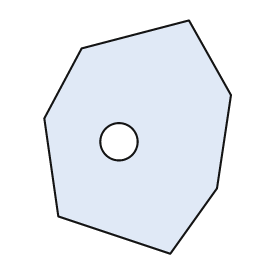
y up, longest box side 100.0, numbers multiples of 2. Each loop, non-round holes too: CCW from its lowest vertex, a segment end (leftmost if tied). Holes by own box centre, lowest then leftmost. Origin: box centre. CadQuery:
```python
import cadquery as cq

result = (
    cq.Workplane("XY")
    .moveTo(14.0, -50.0)
    .lineTo(34.0, -22.0)
    .lineTo(40.0, 18.0)
    .lineTo(22.0, 50.0)
    .lineTo(-24.0, 38.0)
    .lineTo(-40.0, 8.0)
    .lineTo(-34.0, -34.0)
    .close()
    .moveTo(-8.0, -2.0)
    .circle(8.0)
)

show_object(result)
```